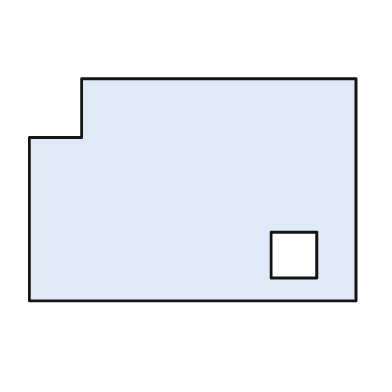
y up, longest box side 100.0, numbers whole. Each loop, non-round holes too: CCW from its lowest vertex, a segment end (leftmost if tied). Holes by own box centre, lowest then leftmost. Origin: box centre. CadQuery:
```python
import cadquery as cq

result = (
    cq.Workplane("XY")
    .moveTo(-50.0, -34.0)
    .lineTo(50.0, -34.0)
    .lineTo(50.0, 34.0)
    .lineTo(-34.0, 34.0)
    .lineTo(-34.0, 16.0)
    .lineTo(-50.0, 16.0)
    .close()
    .moveTo(24.0, -27.0)
    .lineTo(38.0, -27.0)
    .lineTo(38.0, -13.0)
    .lineTo(24.0, -13.0)
    .close()
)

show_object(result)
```